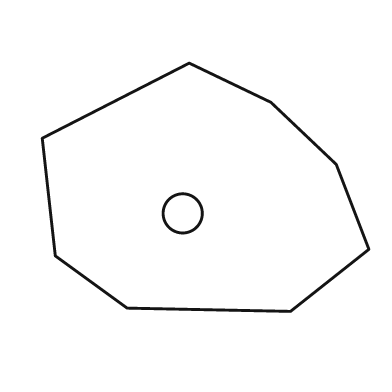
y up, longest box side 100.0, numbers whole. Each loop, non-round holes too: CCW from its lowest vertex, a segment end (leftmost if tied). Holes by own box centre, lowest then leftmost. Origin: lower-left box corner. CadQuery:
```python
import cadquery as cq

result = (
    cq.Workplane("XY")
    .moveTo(76.0, 0.0)
    .lineTo(100.0, 19.0)
    .lineTo(90.0, 45.0)
    .lineTo(70.0, 64.0)
    .lineTo(45.0, 76.0)
    .lineTo(0.0, 53.0)
    .lineTo(4.0, 17.0)
    .lineTo(26.0, 1.0)
    .close()
    .moveTo(43.0, 30.0)
    .circle(6.0)
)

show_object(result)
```